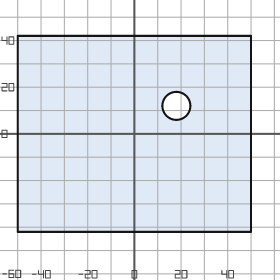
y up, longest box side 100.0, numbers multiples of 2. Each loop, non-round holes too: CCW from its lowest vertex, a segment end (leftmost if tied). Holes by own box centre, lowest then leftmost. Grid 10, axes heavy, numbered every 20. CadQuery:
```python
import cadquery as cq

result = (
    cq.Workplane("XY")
    .moveTo(-50.0, -42.0)
    .lineTo(50.0, -42.0)
    .lineTo(50.0, 42.0)
    .lineTo(-50.0, 42.0)
    .close()
    .moveTo(18.0, 12.0)
    .circle(6.0)
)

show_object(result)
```